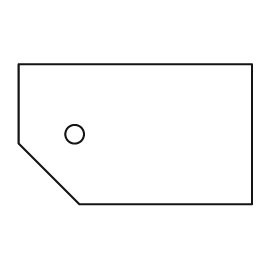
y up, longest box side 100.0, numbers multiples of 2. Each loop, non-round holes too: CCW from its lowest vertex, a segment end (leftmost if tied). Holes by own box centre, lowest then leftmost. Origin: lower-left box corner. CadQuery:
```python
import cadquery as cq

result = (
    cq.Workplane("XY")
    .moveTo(26.0, 0.0)
    .lineTo(100.0, 0.0)
    .lineTo(100.0, 60.0)
    .lineTo(0.0, 60.0)
    .lineTo(0.0, 26.0)
    .close()
    .moveTo(24.0, 30.0)
    .circle(4.0)
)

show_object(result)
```